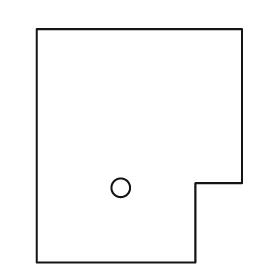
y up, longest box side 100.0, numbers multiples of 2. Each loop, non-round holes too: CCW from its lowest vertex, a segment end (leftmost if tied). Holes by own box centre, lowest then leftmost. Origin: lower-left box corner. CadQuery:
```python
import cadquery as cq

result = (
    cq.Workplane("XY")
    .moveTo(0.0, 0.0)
    .lineTo(68.0, 0.0)
    .lineTo(68.0, 34.0)
    .lineTo(88.0, 34.0)
    .lineTo(88.0, 100.0)
    .lineTo(0.0, 100.0)
    .close()
    .moveTo(36.0, 32.0)
    .circle(4.0)
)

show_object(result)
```